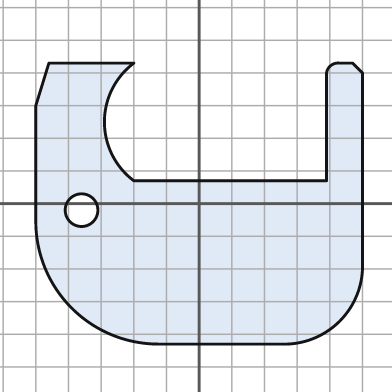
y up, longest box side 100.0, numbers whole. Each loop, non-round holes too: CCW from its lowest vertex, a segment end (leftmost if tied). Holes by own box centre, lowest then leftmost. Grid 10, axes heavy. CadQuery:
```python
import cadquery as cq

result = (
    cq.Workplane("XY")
    .moveTo(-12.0, -43.0)
    .lineTo(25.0, -43.0)
    .threePointArc((43.0, -36.0), (50.0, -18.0))
    .lineTo(50.0, 40.0)
    .lineTo(47.0, 43.0)
    .lineTo(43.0, 43.0)
    .threePointArc((40.0, 42.0), (39.0, 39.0))
    .lineTo(39.0, 7.0)
    .lineTo(-20.0, 7.0)
    .threePointArc((-29.0, 25.0), (-20.0, 43.0))
    .lineTo(-46.0, 43.0)
    .lineTo(-50.0, 30.0)
    .lineTo(-50.0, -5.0)
    .threePointArc((-39.0, -32.0), (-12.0, -43.0))
    .close()
    .moveTo(-36.0, -2.0)
    .circle(5.0)
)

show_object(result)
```